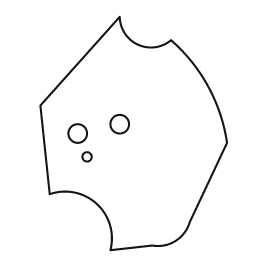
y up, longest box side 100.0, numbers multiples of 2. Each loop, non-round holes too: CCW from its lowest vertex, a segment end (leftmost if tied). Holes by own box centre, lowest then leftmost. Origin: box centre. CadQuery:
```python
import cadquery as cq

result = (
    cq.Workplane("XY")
    .moveTo(-10.0, -50.0)
    .lineTo(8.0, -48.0)
    .threePointArc((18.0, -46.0), (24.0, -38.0))
    .lineTo(40.0, -4.0)
    .threePointArc((32.0, 20.0), (16.0, 40.0))
    .threePointArc((2.0, 38.0), (-6.0, 50.0))
    .lineTo(-40.0, 12.0)
    .lineTo(-36.0, -26.0)
    .threePointArc((-16.0, -30.0), (-10.0, -50.0))
    .close()
    .moveTo(-20.0, -10.0)
    .circle(2.0)
    .moveTo(-24.0, 0.0)
    .circle(4.0)
    .moveTo(-6.0, 4.0)
    .circle(4.0)
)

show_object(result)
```